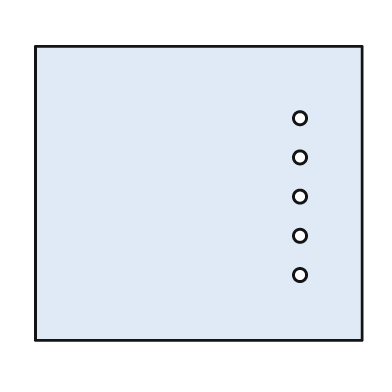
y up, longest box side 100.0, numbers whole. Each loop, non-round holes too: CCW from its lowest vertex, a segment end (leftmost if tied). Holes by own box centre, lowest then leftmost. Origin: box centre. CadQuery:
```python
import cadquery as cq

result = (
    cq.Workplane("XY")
    .moveTo(-50.0, -45.0)
    .lineTo(50.0, -45.0)
    .lineTo(50.0, 45.0)
    .lineTo(-50.0, 45.0)
    .close()
    .moveTo(31.0, -25.0)
    .circle(2.0)
    .moveTo(31.0, -13.0)
    .circle(2.0)
    .moveTo(31.0, -1.0)
    .circle(2.0)
    .moveTo(31.0, 11.0)
    .circle(2.0)
    .moveTo(31.0, 23.0)
    .circle(2.0)
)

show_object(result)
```